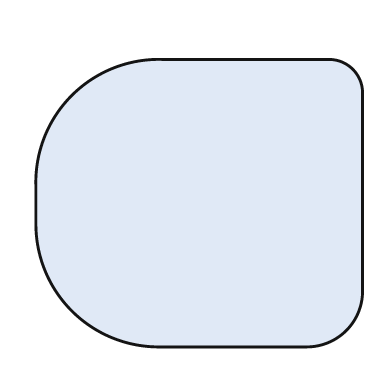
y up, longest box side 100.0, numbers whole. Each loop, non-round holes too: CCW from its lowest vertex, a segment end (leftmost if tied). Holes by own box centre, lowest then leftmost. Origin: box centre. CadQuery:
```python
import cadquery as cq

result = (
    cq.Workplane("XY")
    .moveTo(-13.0, -44.0)
    .lineTo(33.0, -44.0)
    .threePointArc((45.0, -39.0), (50.0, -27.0))
    .lineTo(50.0, 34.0)
    .threePointArc((47.0, 41.0), (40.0, 44.0))
    .lineTo(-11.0, 44.0)
    .threePointArc((-39.0, 33.0), (-50.0, 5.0))
    .lineTo(-50.0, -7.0)
    .threePointArc((-39.0, -33.0), (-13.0, -44.0))
    .close()
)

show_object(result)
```